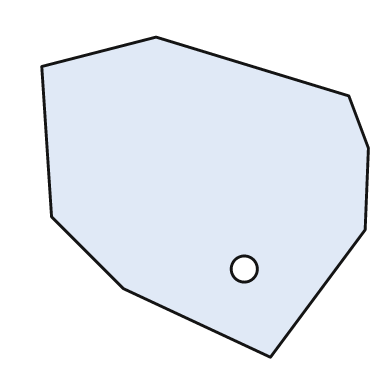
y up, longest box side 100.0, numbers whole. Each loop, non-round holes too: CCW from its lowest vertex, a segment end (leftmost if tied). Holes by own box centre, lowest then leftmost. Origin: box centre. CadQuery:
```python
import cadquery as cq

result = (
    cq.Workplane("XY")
    .moveTo(20.0, -49.0)
    .lineTo(49.0, -10.0)
    .lineTo(50.0, 15.0)
    .lineTo(44.0, 31.0)
    .lineTo(-15.0, 49.0)
    .lineTo(-50.0, 40.0)
    .lineTo(-47.0, -6.0)
    .lineTo(-25.0, -28.0)
    .close()
    .moveTo(12.0, -22.0)
    .circle(4.0)
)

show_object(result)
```